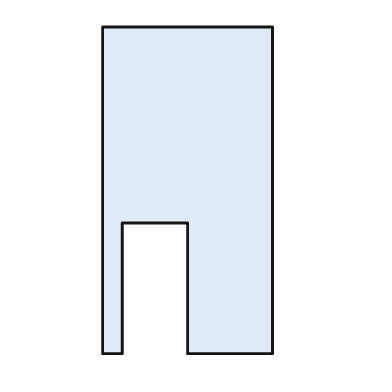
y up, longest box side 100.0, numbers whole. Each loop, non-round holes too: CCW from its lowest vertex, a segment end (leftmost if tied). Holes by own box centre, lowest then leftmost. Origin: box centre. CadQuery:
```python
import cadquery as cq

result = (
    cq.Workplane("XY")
    .moveTo(-26.0, -50.0)
    .lineTo(-20.0, -50.0)
    .lineTo(-20.0, -10.0)
    .lineTo(0.0, -10.0)
    .lineTo(0.0, -50.0)
    .lineTo(26.0, -50.0)
    .lineTo(26.0, 50.0)
    .lineTo(-26.0, 50.0)
    .close()
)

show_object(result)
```